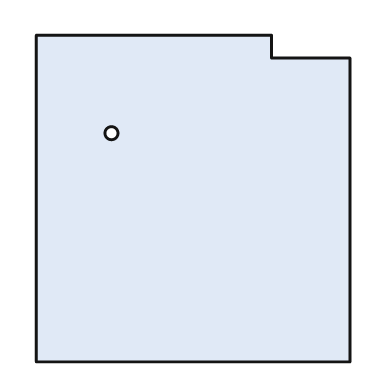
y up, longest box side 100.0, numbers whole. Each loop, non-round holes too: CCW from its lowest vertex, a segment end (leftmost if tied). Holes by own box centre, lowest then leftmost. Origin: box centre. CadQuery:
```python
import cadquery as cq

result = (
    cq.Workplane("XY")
    .moveTo(-48.0, -50.0)
    .lineTo(48.0, -50.0)
    .lineTo(48.0, 43.0)
    .lineTo(24.0, 43.0)
    .lineTo(24.0, 50.0)
    .lineTo(-48.0, 50.0)
    .close()
    .moveTo(-25.0, 20.0)
    .circle(2.0)
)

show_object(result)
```